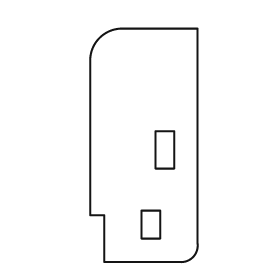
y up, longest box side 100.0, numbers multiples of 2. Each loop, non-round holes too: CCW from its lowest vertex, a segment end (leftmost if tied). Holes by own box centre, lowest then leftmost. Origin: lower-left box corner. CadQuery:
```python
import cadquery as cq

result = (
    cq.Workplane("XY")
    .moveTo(6.0, 0.0)
    .lineTo(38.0, 0.0)
    .threePointArc((44.0, 2.0), (46.0, 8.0))
    .lineTo(46.0, 100.0)
    .lineTo(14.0, 100.0)
    .threePointArc((4.0, 96.0), (0.0, 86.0))
    .lineTo(0.0, 20.0)
    .lineTo(6.0, 20.0)
    .close()
    .moveTo(22.0, 10.0)
    .lineTo(30.0, 10.0)
    .lineTo(30.0, 22.0)
    .lineTo(22.0, 22.0)
    .close()
    .moveTo(28.0, 40.0)
    .lineTo(36.0, 40.0)
    .lineTo(36.0, 56.0)
    .lineTo(28.0, 56.0)
    .close()
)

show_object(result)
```